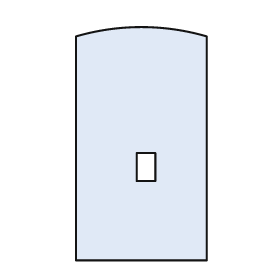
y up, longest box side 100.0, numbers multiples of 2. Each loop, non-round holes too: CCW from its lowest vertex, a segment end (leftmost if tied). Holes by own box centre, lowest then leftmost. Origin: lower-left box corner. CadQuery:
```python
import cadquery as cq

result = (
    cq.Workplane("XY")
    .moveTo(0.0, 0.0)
    .lineTo(56.0, 0.0)
    .lineTo(56.0, 96.0)
    .threePointArc((28.0, 100.0), (0.0, 96.0))
    .close()
    .moveTo(26.0, 34.0)
    .lineTo(34.0, 34.0)
    .lineTo(34.0, 46.0)
    .lineTo(26.0, 46.0)
    .close()
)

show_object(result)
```